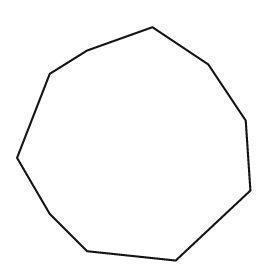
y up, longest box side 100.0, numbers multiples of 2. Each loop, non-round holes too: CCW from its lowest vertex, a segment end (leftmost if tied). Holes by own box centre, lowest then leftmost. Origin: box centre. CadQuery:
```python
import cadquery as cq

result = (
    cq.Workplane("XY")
    .moveTo(18.0, -50.0)
    .lineTo(50.0, -20.0)
    .lineTo(48.0, 10.0)
    .lineTo(32.0, 34.0)
    .lineTo(8.0, 50.0)
    .lineTo(-20.0, 40.0)
    .lineTo(-36.0, 30.0)
    .lineTo(-50.0, -6.0)
    .lineTo(-36.0, -30.0)
    .lineTo(-20.0, -46.0)
    .close()
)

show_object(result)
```